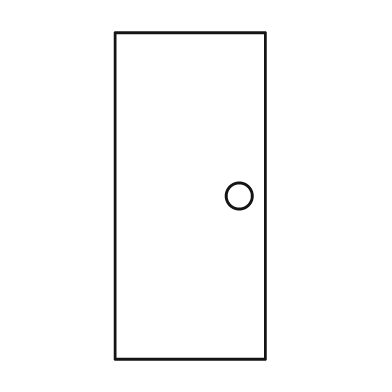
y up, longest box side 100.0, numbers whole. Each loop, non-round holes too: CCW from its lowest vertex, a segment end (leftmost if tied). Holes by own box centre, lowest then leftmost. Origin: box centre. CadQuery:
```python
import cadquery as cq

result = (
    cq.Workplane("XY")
    .moveTo(-23.0, -50.0)
    .lineTo(23.0, -50.0)
    .lineTo(23.0, 50.0)
    .lineTo(-23.0, 50.0)
    .close()
    .moveTo(15.0, 0.0)
    .circle(4.0)
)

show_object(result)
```